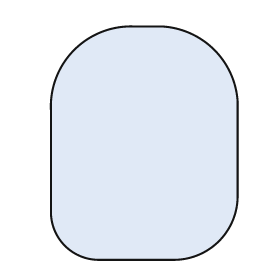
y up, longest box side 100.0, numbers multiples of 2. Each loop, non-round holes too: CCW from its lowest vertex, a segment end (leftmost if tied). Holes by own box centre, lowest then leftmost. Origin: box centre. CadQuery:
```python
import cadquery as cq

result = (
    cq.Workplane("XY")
    .moveTo(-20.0, -50.0)
    .lineTo(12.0, -50.0)
    .threePointArc((32.0, -42.0), (40.0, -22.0))
    .lineTo(40.0, 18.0)
    .threePointArc((30.0, 40.0), (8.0, 50.0))
    .lineTo(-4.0, 50.0)
    .threePointArc((-30.0, 40.0), (-40.0, 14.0))
    .lineTo(-40.0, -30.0)
    .threePointArc((-34.0, -44.0), (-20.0, -50.0))
    .close()
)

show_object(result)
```